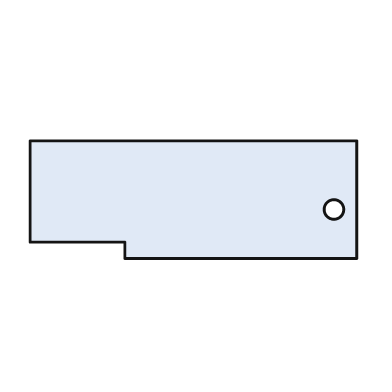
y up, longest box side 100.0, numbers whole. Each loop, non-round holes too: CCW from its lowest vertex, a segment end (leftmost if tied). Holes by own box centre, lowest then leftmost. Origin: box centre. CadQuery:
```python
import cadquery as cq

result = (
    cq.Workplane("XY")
    .moveTo(-21.0, -18.0)
    .lineTo(50.0, -18.0)
    .lineTo(50.0, 18.0)
    .lineTo(-50.0, 18.0)
    .lineTo(-50.0, -13.0)
    .lineTo(-21.0, -13.0)
    .close()
    .moveTo(43.0, -3.0)
    .circle(3.0)
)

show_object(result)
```